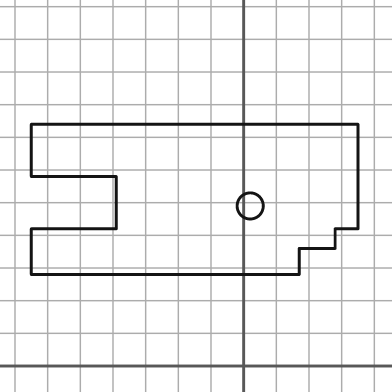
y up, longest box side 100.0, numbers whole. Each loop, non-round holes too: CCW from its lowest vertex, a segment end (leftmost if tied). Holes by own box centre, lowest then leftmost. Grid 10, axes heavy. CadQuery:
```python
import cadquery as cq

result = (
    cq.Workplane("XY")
    .moveTo(-65.0, 28.0)
    .lineTo(17.0, 28.0)
    .lineTo(17.0, 36.0)
    .lineTo(28.0, 36.0)
    .lineTo(28.0, 42.0)
    .lineTo(35.0, 42.0)
    .lineTo(35.0, 74.0)
    .lineTo(-65.0, 74.0)
    .lineTo(-65.0, 58.0)
    .lineTo(-39.0, 58.0)
    .lineTo(-39.0, 42.0)
    .lineTo(-65.0, 42.0)
    .close()
    .moveTo(2.0, 49.0)
    .circle(4.0)
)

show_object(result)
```